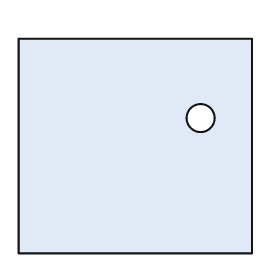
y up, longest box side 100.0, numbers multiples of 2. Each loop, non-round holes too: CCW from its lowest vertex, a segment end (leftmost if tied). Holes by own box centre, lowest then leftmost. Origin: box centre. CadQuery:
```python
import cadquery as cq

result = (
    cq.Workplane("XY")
    .moveTo(-50.0, -46.0)
    .lineTo(50.0, -46.0)
    .lineTo(50.0, 46.0)
    .lineTo(-50.0, 46.0)
    .close()
    .moveTo(28.0, 12.0)
    .circle(6.0)
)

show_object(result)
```